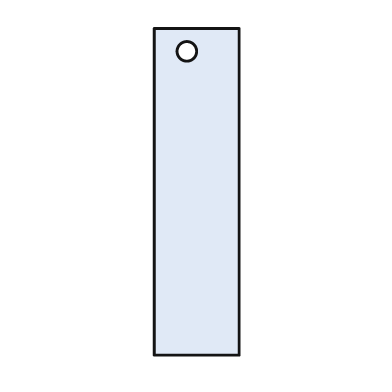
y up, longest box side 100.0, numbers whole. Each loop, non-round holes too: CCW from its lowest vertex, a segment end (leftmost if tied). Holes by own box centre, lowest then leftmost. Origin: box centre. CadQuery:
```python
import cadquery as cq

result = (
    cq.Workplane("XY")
    .moveTo(-13.0, -50.0)
    .lineTo(13.0, -50.0)
    .lineTo(13.0, 50.0)
    .lineTo(-13.0, 50.0)
    .close()
    .moveTo(-3.0, 43.0)
    .circle(3.0)
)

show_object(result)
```